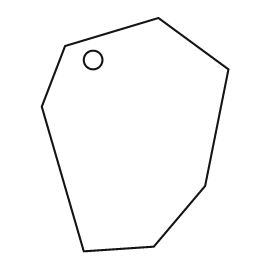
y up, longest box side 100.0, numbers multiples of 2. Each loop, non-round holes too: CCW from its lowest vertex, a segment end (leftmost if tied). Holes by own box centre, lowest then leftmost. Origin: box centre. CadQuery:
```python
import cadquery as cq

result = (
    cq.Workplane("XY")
    .moveTo(-22.0, -50.0)
    .lineTo(8.0, -48.0)
    .lineTo(30.0, -22.0)
    .lineTo(40.0, 28.0)
    .lineTo(10.0, 50.0)
    .lineTo(-30.0, 38.0)
    .lineTo(-40.0, 12.0)
    .close()
    .moveTo(-18.0, 32.0)
    .circle(4.0)
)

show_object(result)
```